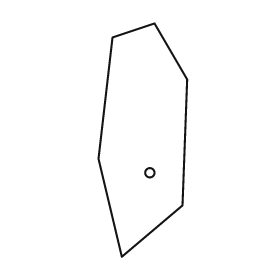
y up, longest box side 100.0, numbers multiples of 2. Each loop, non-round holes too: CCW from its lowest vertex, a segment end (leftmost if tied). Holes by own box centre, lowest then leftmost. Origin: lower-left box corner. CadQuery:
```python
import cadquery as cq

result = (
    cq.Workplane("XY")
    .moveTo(10.0, 0.0)
    .lineTo(36.0, 22.0)
    .lineTo(38.0, 76.0)
    .lineTo(24.0, 100.0)
    .lineTo(6.0, 94.0)
    .lineTo(0.0, 42.0)
    .close()
    .moveTo(22.0, 36.0)
    .circle(2.0)
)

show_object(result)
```